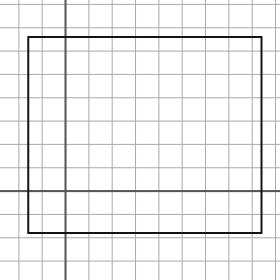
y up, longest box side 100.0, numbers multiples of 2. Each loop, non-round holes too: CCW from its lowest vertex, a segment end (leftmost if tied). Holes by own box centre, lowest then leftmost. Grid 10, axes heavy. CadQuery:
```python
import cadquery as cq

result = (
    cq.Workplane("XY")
    .moveTo(-16.0, -18.0)
    .lineTo(84.0, -18.0)
    .lineTo(84.0, 66.0)
    .lineTo(-16.0, 66.0)
    .close()
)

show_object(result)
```